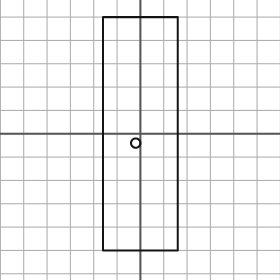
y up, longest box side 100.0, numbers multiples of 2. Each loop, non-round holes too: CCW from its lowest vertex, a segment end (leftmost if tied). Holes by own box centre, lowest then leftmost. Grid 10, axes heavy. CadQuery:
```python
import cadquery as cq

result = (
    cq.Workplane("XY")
    .moveTo(-16.0, -50.0)
    .lineTo(16.0, -50.0)
    .lineTo(16.0, 50.0)
    .lineTo(-16.0, 50.0)
    .close()
    .moveTo(-2.0, -4.0)
    .circle(2.0)
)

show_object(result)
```